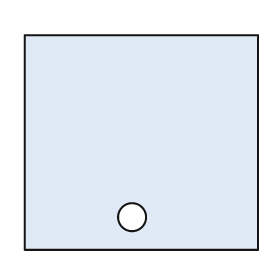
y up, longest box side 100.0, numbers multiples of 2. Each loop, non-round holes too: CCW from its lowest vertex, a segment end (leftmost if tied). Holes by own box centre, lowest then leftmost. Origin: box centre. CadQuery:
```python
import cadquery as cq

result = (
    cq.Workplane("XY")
    .moveTo(-50.0, -46.0)
    .lineTo(50.0, -46.0)
    .lineTo(50.0, 46.0)
    .lineTo(-50.0, 46.0)
    .close()
    .moveTo(-4.0, -32.0)
    .circle(6.0)
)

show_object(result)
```